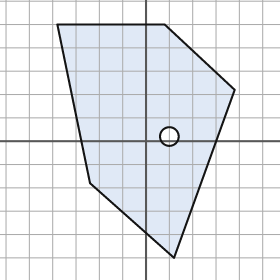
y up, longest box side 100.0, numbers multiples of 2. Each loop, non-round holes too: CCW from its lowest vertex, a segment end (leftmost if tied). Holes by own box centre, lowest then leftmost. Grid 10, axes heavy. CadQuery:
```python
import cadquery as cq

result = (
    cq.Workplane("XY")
    .moveTo(12.0, -50.0)
    .lineTo(38.0, 22.0)
    .lineTo(8.0, 50.0)
    .lineTo(-38.0, 50.0)
    .lineTo(-24.0, -18.0)
    .close()
    .moveTo(10.0, 2.0)
    .circle(4.0)
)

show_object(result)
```